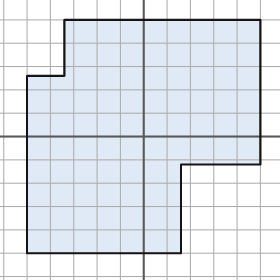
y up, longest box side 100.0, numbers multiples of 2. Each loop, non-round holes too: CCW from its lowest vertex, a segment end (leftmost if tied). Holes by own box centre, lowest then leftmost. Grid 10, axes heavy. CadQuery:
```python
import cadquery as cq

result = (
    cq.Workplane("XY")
    .moveTo(-50.0, -50.0)
    .lineTo(16.0, -50.0)
    .lineTo(16.0, -12.0)
    .lineTo(50.0, -12.0)
    .lineTo(50.0, 50.0)
    .lineTo(-34.0, 50.0)
    .lineTo(-34.0, 26.0)
    .lineTo(-50.0, 26.0)
    .close()
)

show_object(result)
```